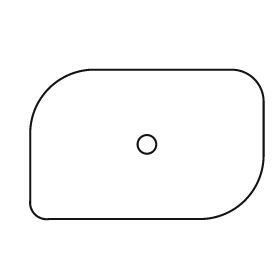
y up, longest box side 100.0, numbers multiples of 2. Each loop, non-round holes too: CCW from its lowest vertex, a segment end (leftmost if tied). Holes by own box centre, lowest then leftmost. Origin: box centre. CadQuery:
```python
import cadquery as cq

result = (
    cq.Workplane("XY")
    .moveTo(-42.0, -32.0)
    .lineTo(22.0, -32.0)
    .threePointArc((42.0, -24.0), (50.0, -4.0))
    .lineTo(50.0, 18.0)
    .threePointArc((46.0, 28.0), (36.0, 32.0))
    .lineTo(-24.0, 32.0)
    .threePointArc((-42.0, 24.0), (-50.0, 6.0))
    .lineTo(-50.0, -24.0)
    .threePointArc((-48.0, -30.0), (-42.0, -32.0))
    .close()
    .moveTo(0.0, 0.0)
    .circle(4.0)
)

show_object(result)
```